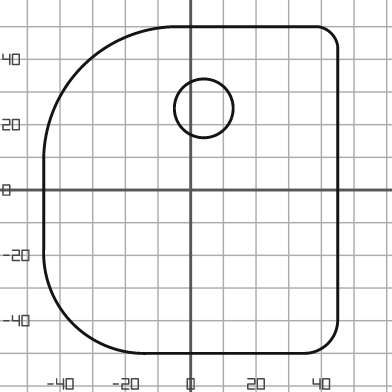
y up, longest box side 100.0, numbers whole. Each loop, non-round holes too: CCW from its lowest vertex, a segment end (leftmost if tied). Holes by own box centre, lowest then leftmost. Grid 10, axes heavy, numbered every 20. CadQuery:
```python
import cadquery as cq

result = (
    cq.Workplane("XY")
    .moveTo(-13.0, -50.0)
    .lineTo(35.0, -50.0)
    .threePointArc((42.0, -47.0), (45.0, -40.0))
    .lineTo(45.0, 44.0)
    .threePointArc((43.0, 48.0), (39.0, 50.0))
    .lineTo(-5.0, 50.0)
    .threePointArc((-33.0, 38.0), (-45.0, 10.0))
    .lineTo(-45.0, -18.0)
    .threePointArc((-36.0, -41.0), (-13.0, -50.0))
    .close()
    .moveTo(4.0, 25.0)
    .circle(9.0)
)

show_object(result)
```